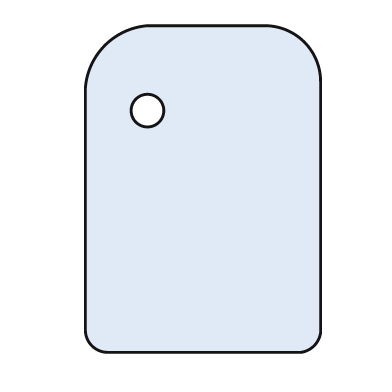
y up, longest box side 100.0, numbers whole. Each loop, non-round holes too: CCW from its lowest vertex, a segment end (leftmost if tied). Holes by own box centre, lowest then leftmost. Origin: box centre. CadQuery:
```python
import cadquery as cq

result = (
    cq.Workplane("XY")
    .moveTo(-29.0, -50.0)
    .lineTo(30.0, -50.0)
    .threePointArc((34.0, -48.0), (36.0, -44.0))
    .lineTo(36.0, 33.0)
    .threePointArc((31.0, 45.0), (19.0, 50.0))
    .lineTo(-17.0, 50.0)
    .threePointArc((-30.0, 44.0), (-36.0, 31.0))
    .lineTo(-36.0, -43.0)
    .threePointArc((-34.0, -48.0), (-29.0, -50.0))
    .close()
    .moveTo(-17.0, 24.0)
    .circle(5.0)
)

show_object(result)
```